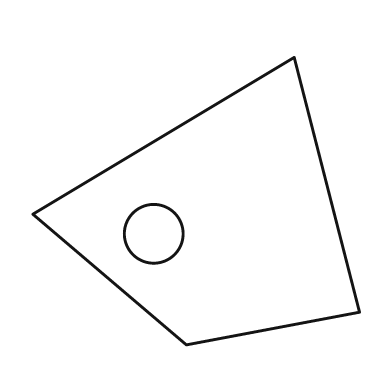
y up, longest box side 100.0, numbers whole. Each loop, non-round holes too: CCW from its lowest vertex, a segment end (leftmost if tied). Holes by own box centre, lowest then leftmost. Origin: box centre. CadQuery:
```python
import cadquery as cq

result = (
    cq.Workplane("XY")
    .moveTo(-3.0, -44.0)
    .lineTo(50.0, -34.0)
    .lineTo(30.0, 44.0)
    .lineTo(-50.0, -4.0)
    .close()
    .moveTo(-13.0, -10.0)
    .circle(9.0)
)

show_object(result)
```